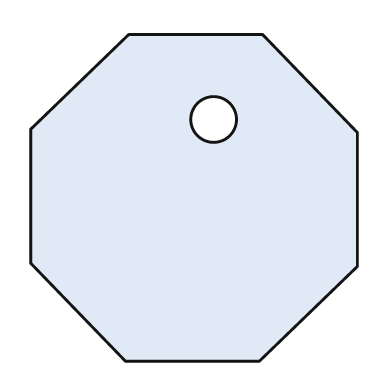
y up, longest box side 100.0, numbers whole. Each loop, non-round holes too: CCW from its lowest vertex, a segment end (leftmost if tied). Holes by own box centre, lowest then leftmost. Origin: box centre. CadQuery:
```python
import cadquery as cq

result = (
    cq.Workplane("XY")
    .moveTo(-21.0, -50.0)
    .lineTo(20.0, -50.0)
    .lineTo(50.0, -21.0)
    .lineTo(50.0, 20.0)
    .lineTo(21.0, 50.0)
    .lineTo(-20.0, 50.0)
    .lineTo(-50.0, 21.0)
    .lineTo(-50.0, -20.0)
    .close()
    .moveTo(6.0, 24.0)
    .circle(7.0)
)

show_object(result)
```